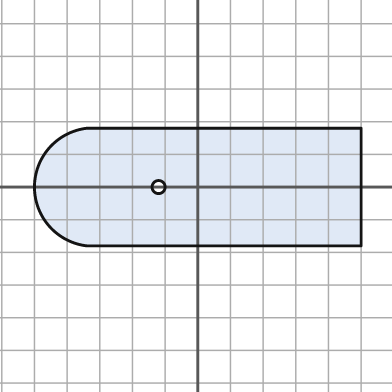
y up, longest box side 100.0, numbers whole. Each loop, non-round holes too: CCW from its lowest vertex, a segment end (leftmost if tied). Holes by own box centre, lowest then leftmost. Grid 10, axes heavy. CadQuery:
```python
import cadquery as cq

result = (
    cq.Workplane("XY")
    .moveTo(-34.0, -18.0)
    .lineTo(50.0, -18.0)
    .lineTo(50.0, 18.0)
    .lineTo(-34.0, 18.0)
    .threePointArc((-50.0, 0.0), (-34.0, -18.0))
    .close()
    .moveTo(-12.0, 0.0)
    .circle(2.0)
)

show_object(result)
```